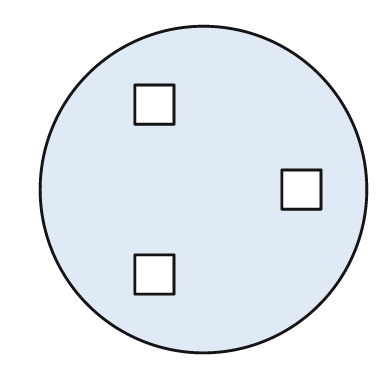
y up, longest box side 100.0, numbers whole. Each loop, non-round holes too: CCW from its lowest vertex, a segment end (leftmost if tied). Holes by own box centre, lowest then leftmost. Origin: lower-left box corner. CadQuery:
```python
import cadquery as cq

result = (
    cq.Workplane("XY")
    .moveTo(50.0, 50.0)
    .circle(50.0)
    .moveTo(29.0, 18.0)
    .lineTo(41.0, 18.0)
    .lineTo(41.0, 30.0)
    .lineTo(29.0, 30.0)
    .close()
    .moveTo(74.0, 44.0)
    .lineTo(86.0, 44.0)
    .lineTo(86.0, 56.0)
    .lineTo(74.0, 56.0)
    .close()
    .moveTo(29.0, 70.0)
    .lineTo(41.0, 70.0)
    .lineTo(41.0, 82.0)
    .lineTo(29.0, 82.0)
    .close()
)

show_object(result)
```